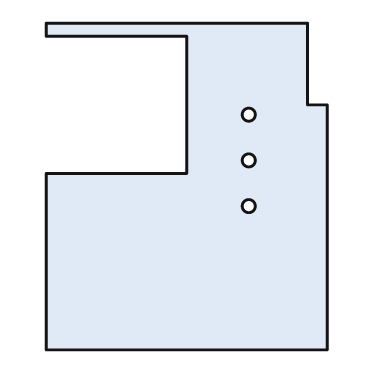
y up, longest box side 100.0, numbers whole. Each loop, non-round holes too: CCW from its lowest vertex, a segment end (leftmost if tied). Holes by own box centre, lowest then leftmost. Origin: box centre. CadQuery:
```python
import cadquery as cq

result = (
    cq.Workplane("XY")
    .moveTo(-43.0, -50.0)
    .lineTo(43.0, -50.0)
    .lineTo(43.0, 25.0)
    .lineTo(37.0, 25.0)
    .lineTo(37.0, 50.0)
    .lineTo(-43.0, 50.0)
    .lineTo(-43.0, 46.0)
    .lineTo(0.0, 46.0)
    .lineTo(0.0, 4.0)
    .lineTo(-43.0, 4.0)
    .close()
    .moveTo(19.0, -6.0)
    .circle(2.0)
    .moveTo(19.0, 8.0)
    .circle(2.0)
    .moveTo(19.0, 22.0)
    .circle(2.0)
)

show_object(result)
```